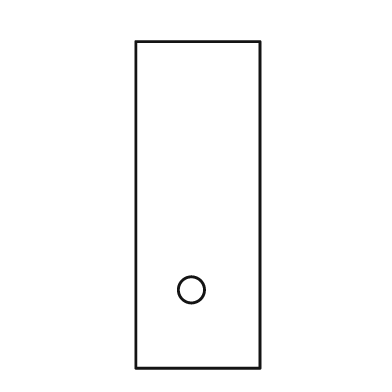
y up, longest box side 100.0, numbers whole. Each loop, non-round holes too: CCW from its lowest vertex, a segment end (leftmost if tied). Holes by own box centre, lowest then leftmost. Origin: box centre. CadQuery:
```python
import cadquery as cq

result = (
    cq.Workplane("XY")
    .moveTo(-19.0, -50.0)
    .lineTo(19.0, -50.0)
    .lineTo(19.0, 50.0)
    .lineTo(-19.0, 50.0)
    .close()
    .moveTo(-2.0, -26.0)
    .circle(4.0)
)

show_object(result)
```